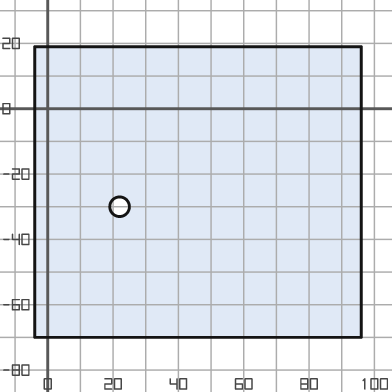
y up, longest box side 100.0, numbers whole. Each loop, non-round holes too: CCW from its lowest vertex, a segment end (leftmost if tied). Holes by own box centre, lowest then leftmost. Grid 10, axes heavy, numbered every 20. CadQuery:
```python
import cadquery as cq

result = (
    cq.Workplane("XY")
    .moveTo(-4.0, -70.0)
    .lineTo(96.0, -70.0)
    .lineTo(96.0, 19.0)
    .lineTo(-4.0, 19.0)
    .close()
    .moveTo(22.0, -30.0)
    .circle(3.0)
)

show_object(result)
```